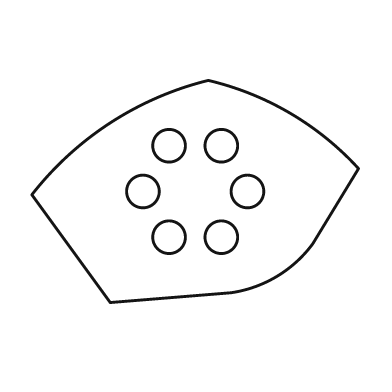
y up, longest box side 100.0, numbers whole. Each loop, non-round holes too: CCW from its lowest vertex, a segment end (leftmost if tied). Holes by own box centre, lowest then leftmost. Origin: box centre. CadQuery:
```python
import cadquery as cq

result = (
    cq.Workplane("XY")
    .moveTo(-26.0, -34.0)
    .lineTo(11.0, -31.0)
    .threePointArc((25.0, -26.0), (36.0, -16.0))
    .lineTo(50.0, 7.0)
    .threePointArc((29.0, 24.0), (4.0, 34.0))
    .threePointArc((-26.0, 21.0), (-50.0, -1.0))
    .close()
    .moveTo(-8.0, -14.0)
    .circle(5.0)
    .moveTo(8.0, -14.0)
    .circle(5.0)
    .moveTo(-16.0, 0.0)
    .circle(5.0)
    .moveTo(16.0, 0.0)
    .circle(5.0)
    .moveTo(-8.0, 14.0)
    .circle(5.0)
    .moveTo(8.0, 14.0)
    .circle(5.0)
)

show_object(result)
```